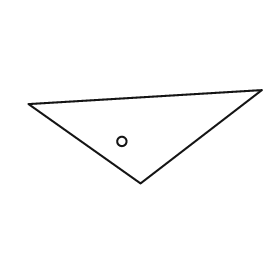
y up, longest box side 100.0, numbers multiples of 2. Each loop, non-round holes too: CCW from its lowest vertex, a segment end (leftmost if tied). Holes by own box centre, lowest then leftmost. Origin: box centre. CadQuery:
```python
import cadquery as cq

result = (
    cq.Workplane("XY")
    .moveTo(-2.0, -20.0)
    .lineTo(50.0, 20.0)
    .lineTo(-50.0, 14.0)
    .close()
    .moveTo(-10.0, -2.0)
    .circle(2.0)
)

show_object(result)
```